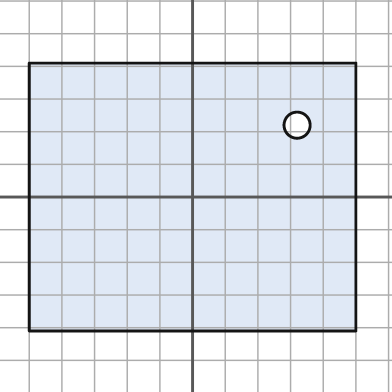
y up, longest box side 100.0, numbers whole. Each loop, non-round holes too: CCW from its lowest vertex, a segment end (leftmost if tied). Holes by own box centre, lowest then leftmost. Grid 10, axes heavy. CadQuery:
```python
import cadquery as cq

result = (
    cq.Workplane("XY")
    .moveTo(-50.0, -41.0)
    .lineTo(50.0, -41.0)
    .lineTo(50.0, 41.0)
    .lineTo(-50.0, 41.0)
    .close()
    .moveTo(32.0, 22.0)
    .circle(4.0)
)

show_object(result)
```